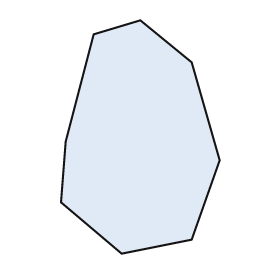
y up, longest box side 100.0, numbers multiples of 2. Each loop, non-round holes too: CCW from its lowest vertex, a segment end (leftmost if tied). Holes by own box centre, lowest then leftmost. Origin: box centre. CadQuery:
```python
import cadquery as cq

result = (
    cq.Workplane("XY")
    .moveTo(-8.0, -50.0)
    .lineTo(22.0, -44.0)
    .lineTo(34.0, -10.0)
    .lineTo(22.0, 32.0)
    .lineTo(0.0, 50.0)
    .lineTo(-20.0, 44.0)
    .lineTo(-32.0, -2.0)
    .lineTo(-34.0, -28.0)
    .close()
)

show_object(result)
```